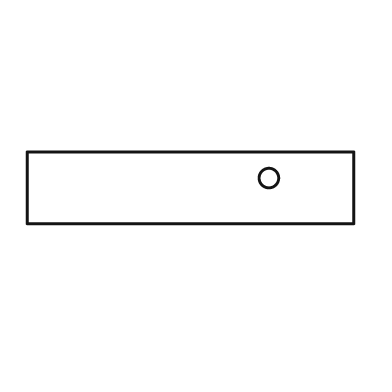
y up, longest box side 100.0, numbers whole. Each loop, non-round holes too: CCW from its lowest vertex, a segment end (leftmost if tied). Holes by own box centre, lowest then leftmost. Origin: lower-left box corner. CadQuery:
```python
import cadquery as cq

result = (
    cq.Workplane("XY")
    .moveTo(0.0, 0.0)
    .lineTo(100.0, 0.0)
    .lineTo(100.0, 22.0)
    .lineTo(0.0, 22.0)
    .close()
    .moveTo(74.0, 14.0)
    .circle(3.0)
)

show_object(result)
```